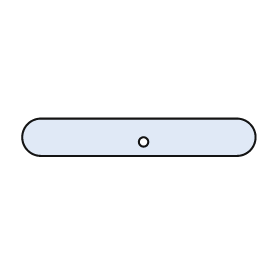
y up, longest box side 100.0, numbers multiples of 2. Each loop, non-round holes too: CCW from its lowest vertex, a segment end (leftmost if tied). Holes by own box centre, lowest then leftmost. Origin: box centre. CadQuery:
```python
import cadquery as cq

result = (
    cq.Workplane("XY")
    .moveTo(-42.0, -8.0)
    .lineTo(42.0, -8.0)
    .threePointArc((50.0, 0.0), (42.0, 8.0))
    .lineTo(-42.0, 8.0)
    .threePointArc((-50.0, 0.0), (-42.0, -8.0))
    .close()
    .moveTo(2.0, -2.0)
    .circle(2.0)
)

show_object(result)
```